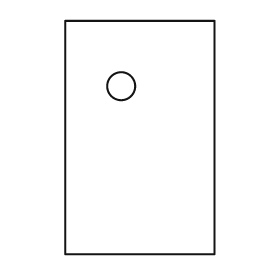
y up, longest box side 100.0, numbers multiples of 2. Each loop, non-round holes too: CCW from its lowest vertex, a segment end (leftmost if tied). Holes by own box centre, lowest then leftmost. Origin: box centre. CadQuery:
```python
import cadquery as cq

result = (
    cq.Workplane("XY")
    .moveTo(-32.0, -50.0)
    .lineTo(32.0, -50.0)
    .lineTo(32.0, 50.0)
    .lineTo(-32.0, 50.0)
    .close()
    .moveTo(-8.0, 22.0)
    .circle(6.0)
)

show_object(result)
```